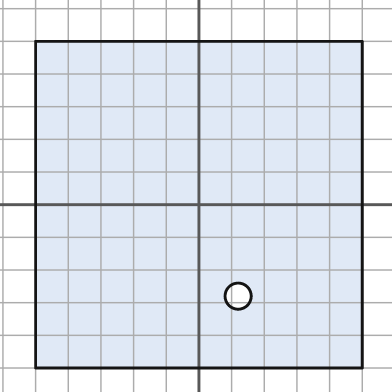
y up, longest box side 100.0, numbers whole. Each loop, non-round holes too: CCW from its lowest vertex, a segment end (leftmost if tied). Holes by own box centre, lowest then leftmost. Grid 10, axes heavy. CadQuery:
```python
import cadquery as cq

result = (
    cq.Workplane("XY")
    .moveTo(-50.0, -50.0)
    .lineTo(50.0, -50.0)
    .lineTo(50.0, 50.0)
    .lineTo(-50.0, 50.0)
    .close()
    .moveTo(12.0, -28.0)
    .circle(4.0)
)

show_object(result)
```